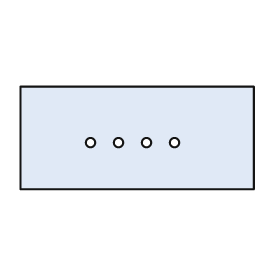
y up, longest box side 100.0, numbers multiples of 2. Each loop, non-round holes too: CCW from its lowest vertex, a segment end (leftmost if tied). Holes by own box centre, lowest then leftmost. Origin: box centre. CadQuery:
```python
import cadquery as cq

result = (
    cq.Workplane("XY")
    .moveTo(-50.0, -22.0)
    .lineTo(50.0, -22.0)
    .lineTo(50.0, 22.0)
    .lineTo(-50.0, 22.0)
    .close()
    .moveTo(-20.0, -2.0)
    .circle(2.0)
    .moveTo(-8.0, -2.0)
    .circle(2.0)
    .moveTo(4.0, -2.0)
    .circle(2.0)
    .moveTo(16.0, -2.0)
    .circle(2.0)
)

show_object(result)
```